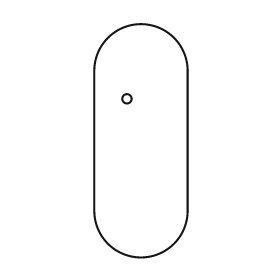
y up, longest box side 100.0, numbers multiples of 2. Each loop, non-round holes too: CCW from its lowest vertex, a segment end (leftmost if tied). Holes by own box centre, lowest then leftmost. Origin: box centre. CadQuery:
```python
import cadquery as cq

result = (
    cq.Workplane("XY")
    .moveTo(-20.0, -30.0)
    .threePointArc((0.0, -50.0), (20.0, -30.0))
    .lineTo(20.0, 30.0)
    .threePointArc((0.0, 50.0), (-20.0, 30.0))
    .close()
    .moveTo(-6.0, 18.0)
    .circle(2.0)
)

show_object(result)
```